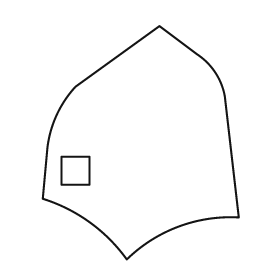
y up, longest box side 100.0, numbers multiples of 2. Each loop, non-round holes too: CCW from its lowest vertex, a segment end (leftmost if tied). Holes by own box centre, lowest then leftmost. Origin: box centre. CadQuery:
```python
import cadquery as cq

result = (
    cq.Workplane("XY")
    .moveTo(-6.0, -50.0)
    .threePointArc((16.0, -36.0), (42.0, -32.0))
    .lineTo(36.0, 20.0)
    .threePointArc((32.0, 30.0), (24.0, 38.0))
    .lineTo(8.0, 50.0)
    .lineTo(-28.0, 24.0)
    .threePointArc((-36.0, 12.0), (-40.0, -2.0))
    .lineTo(-42.0, -24.0)
    .threePointArc((-22.0, -34.0), (-6.0, -50.0))
    .close()
    .moveTo(-34.0, -18.0)
    .lineTo(-22.0, -18.0)
    .lineTo(-22.0, -6.0)
    .lineTo(-34.0, -6.0)
    .close()
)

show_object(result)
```